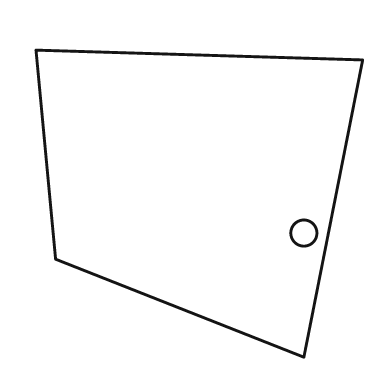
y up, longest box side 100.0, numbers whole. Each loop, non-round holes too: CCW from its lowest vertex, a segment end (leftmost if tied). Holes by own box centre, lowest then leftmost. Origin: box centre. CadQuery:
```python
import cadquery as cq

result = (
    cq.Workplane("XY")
    .moveTo(32.0, -47.0)
    .lineTo(50.0, 44.0)
    .lineTo(-50.0, 47.0)
    .lineTo(-44.0, -17.0)
    .close()
    .moveTo(32.0, -9.0)
    .circle(4.0)
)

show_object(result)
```